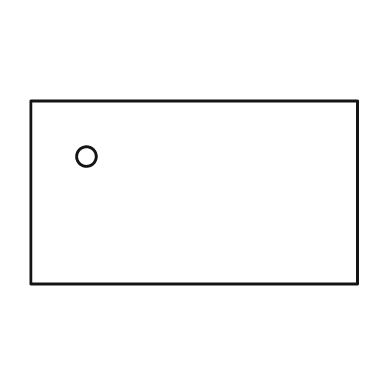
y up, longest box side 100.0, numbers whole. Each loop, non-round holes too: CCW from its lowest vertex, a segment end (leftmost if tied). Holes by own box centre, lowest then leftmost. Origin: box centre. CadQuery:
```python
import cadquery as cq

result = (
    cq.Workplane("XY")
    .moveTo(-50.0, -28.0)
    .lineTo(50.0, -28.0)
    .lineTo(50.0, 28.0)
    .lineTo(-50.0, 28.0)
    .close()
    .moveTo(-33.0, 11.0)
    .circle(3.0)
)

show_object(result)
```